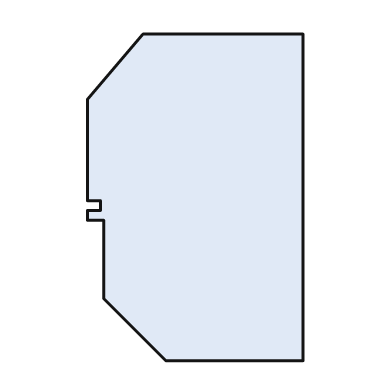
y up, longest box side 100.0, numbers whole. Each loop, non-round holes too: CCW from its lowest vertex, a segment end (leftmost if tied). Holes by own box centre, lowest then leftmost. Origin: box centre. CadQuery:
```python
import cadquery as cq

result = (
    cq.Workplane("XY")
    .moveTo(-9.0, -50.0)
    .lineTo(33.0, -50.0)
    .lineTo(33.0, 50.0)
    .lineTo(-16.0, 50.0)
    .lineTo(-33.0, 30.0)
    .lineTo(-33.0, -1.0)
    .lineTo(-29.0, -1.0)
    .lineTo(-29.0, -4.0)
    .lineTo(-33.0, -4.0)
    .lineTo(-33.0, -7.0)
    .lineTo(-28.0, -7.0)
    .lineTo(-28.0, -31.0)
    .close()
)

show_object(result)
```